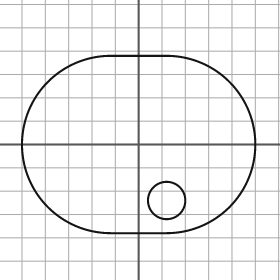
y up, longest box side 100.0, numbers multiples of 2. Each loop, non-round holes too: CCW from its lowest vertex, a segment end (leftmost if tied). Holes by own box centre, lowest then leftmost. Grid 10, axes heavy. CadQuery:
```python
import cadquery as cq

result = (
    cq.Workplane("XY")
    .moveTo(-12.0, -38.0)
    .lineTo(12.0, -38.0)
    .threePointArc((50.0, 0.0), (12.0, 38.0))
    .lineTo(-12.0, 38.0)
    .threePointArc((-50.0, 0.0), (-12.0, -38.0))
    .close()
    .moveTo(12.0, -24.0)
    .circle(8.0)
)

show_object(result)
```